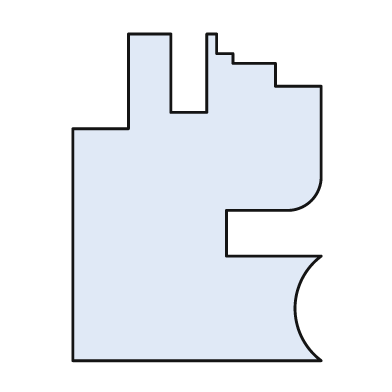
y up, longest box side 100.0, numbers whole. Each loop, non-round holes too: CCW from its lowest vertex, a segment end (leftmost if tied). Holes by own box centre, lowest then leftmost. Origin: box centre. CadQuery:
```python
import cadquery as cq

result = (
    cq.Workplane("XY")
    .moveTo(-38.0, -50.0)
    .lineTo(38.0, -50.0)
    .threePointArc((30.0, -34.0), (38.0, -18.0))
    .lineTo(9.0, -18.0)
    .lineTo(9.0, -4.0)
    .lineTo(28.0, -4.0)
    .threePointArc((35.0, -1.0), (38.0, 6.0))
    .lineTo(38.0, 34.0)
    .lineTo(24.0, 34.0)
    .lineTo(24.0, 41.0)
    .lineTo(11.0, 41.0)
    .lineTo(11.0, 44.0)
    .lineTo(6.0, 44.0)
    .lineTo(6.0, 50.0)
    .lineTo(3.0, 50.0)
    .lineTo(3.0, 26.0)
    .lineTo(-8.0, 26.0)
    .lineTo(-8.0, 50.0)
    .lineTo(-21.0, 50.0)
    .lineTo(-21.0, 21.0)
    .lineTo(-38.0, 21.0)
    .close()
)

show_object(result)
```